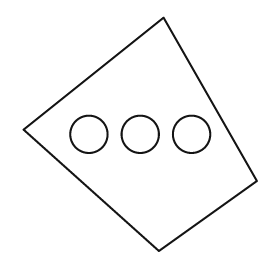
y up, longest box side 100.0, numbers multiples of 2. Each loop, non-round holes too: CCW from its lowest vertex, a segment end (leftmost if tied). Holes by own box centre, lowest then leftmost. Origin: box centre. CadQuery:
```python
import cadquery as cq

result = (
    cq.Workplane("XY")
    .moveTo(8.0, -50.0)
    .lineTo(50.0, -20.0)
    .lineTo(10.0, 50.0)
    .lineTo(-50.0, 2.0)
    .close()
    .moveTo(-22.0, 0.0)
    .circle(8.0)
    .moveTo(0.0, 0.0)
    .circle(8.0)
    .moveTo(22.0, 0.0)
    .circle(8.0)
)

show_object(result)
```